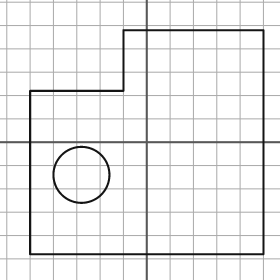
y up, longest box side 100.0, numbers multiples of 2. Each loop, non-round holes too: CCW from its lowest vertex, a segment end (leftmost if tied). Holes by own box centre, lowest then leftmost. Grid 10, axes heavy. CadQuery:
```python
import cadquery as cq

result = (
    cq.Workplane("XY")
    .moveTo(-50.0, -48.0)
    .lineTo(50.0, -48.0)
    .lineTo(50.0, 48.0)
    .lineTo(-10.0, 48.0)
    .lineTo(-10.0, 22.0)
    .lineTo(-50.0, 22.0)
    .close()
    .moveTo(-28.0, -14.0)
    .circle(12.0)
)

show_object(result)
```